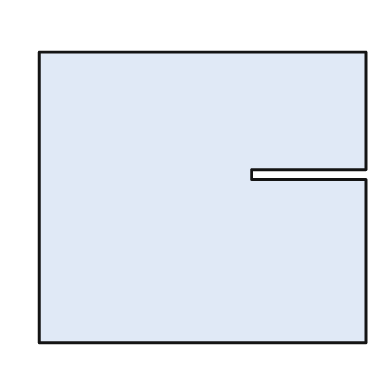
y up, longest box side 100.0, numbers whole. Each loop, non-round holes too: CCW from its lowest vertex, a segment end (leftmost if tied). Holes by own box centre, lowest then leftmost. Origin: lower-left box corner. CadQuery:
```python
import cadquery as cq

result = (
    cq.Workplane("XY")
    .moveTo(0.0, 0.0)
    .lineTo(100.0, 0.0)
    .lineTo(100.0, 50.0)
    .lineTo(65.0, 50.0)
    .lineTo(65.0, 53.0)
    .lineTo(100.0, 53.0)
    .lineTo(100.0, 89.0)
    .lineTo(0.0, 89.0)
    .close()
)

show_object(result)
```